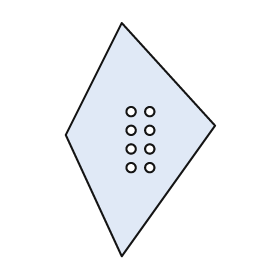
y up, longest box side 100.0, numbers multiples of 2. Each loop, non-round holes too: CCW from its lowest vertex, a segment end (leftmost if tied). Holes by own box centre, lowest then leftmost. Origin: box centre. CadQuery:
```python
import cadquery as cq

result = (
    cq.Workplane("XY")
    .moveTo(-8.0, -50.0)
    .lineTo(32.0, 6.0)
    .lineTo(-8.0, 50.0)
    .lineTo(-32.0, 2.0)
    .close()
    .moveTo(-4.0, -12.0)
    .circle(2.0)
    .moveTo(4.0, -12.0)
    .circle(2.0)
    .moveTo(-4.0, -4.0)
    .circle(2.0)
    .moveTo(4.0, -4.0)
    .circle(2.0)
    .moveTo(-4.0, 4.0)
    .circle(2.0)
    .moveTo(4.0, 4.0)
    .circle(2.0)
    .moveTo(-4.0, 12.0)
    .circle(2.0)
    .moveTo(4.0, 12.0)
    .circle(2.0)
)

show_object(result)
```